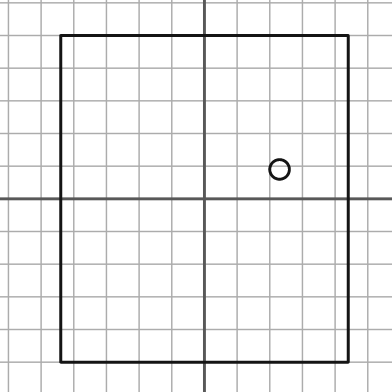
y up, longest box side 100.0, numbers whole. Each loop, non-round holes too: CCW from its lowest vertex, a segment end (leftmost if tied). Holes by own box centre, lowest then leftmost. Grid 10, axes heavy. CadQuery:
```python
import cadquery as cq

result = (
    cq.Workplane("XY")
    .moveTo(-44.0, -50.0)
    .lineTo(44.0, -50.0)
    .lineTo(44.0, 50.0)
    .lineTo(-44.0, 50.0)
    .close()
    .moveTo(23.0, 9.0)
    .circle(3.0)
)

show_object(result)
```